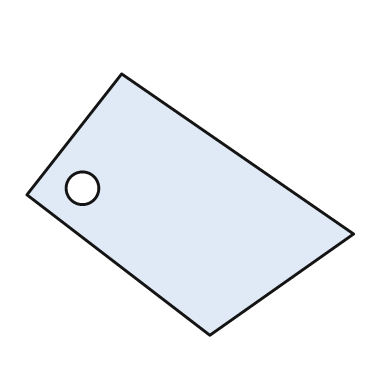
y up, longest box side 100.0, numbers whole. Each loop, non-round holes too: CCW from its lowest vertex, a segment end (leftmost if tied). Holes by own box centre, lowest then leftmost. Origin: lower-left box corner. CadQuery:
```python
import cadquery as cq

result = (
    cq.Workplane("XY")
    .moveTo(56.0, 0.0)
    .lineTo(100.0, 31.0)
    .lineTo(29.0, 80.0)
    .lineTo(0.0, 43.0)
    .close()
    .moveTo(17.0, 45.0)
    .circle(5.0)
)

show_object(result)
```